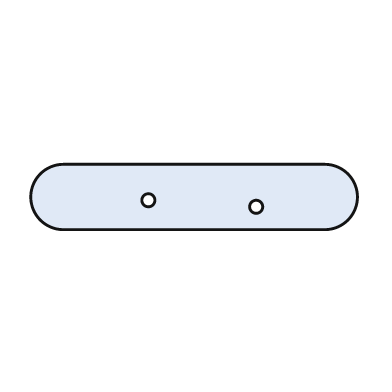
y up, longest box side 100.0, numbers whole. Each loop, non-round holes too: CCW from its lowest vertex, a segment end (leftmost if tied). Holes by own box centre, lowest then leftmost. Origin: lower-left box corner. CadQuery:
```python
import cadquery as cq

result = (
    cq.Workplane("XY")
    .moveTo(10.0, 0.0)
    .lineTo(90.0, 0.0)
    .threePointArc((100.0, 10.0), (90.0, 20.0))
    .lineTo(10.0, 20.0)
    .threePointArc((0.0, 10.0), (10.0, 0.0))
    .close()
    .moveTo(69.0, 7.0)
    .circle(2.0)
    .moveTo(36.0, 9.0)
    .circle(2.0)
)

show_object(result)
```